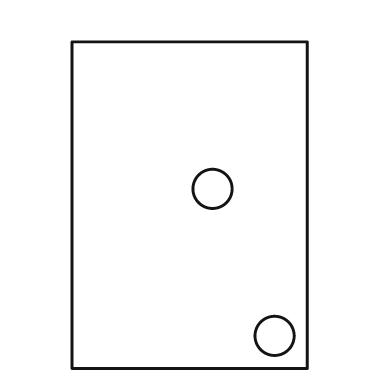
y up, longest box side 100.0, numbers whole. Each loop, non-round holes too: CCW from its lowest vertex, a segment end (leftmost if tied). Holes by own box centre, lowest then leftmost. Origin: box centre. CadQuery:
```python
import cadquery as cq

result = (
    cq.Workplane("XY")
    .moveTo(-36.0, -50.0)
    .lineTo(36.0, -50.0)
    .lineTo(36.0, 50.0)
    .lineTo(-36.0, 50.0)
    .close()
    .moveTo(26.0, -40.0)
    .circle(6.0)
    .moveTo(7.0, 5.0)
    .circle(6.0)
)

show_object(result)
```